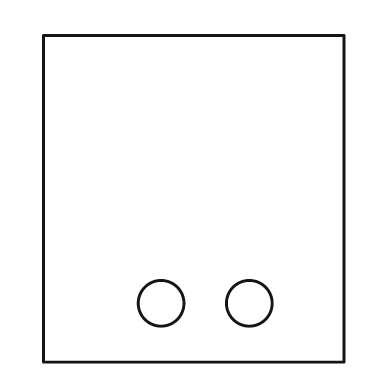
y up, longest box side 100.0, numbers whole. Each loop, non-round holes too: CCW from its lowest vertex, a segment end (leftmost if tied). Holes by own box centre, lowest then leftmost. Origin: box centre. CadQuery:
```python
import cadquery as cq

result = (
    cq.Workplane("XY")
    .moveTo(-46.0, -50.0)
    .lineTo(46.0, -50.0)
    .lineTo(46.0, 50.0)
    .lineTo(-46.0, 50.0)
    .close()
    .moveTo(-10.0, -32.0)
    .circle(7.0)
    .moveTo(17.0, -32.0)
    .circle(7.0)
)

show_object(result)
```